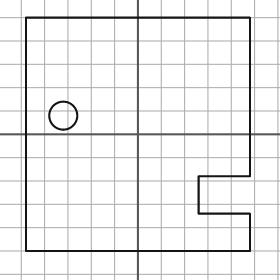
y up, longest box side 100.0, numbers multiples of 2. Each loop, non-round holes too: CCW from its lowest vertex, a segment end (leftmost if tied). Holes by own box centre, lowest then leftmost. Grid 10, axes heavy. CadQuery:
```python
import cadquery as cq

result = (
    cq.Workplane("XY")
    .moveTo(-48.0, -50.0)
    .lineTo(48.0, -50.0)
    .lineTo(48.0, -34.0)
    .lineTo(26.0, -34.0)
    .lineTo(26.0, -18.0)
    .lineTo(48.0, -18.0)
    .lineTo(48.0, 50.0)
    .lineTo(-48.0, 50.0)
    .close()
    .moveTo(-32.0, 8.0)
    .circle(6.0)
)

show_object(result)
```